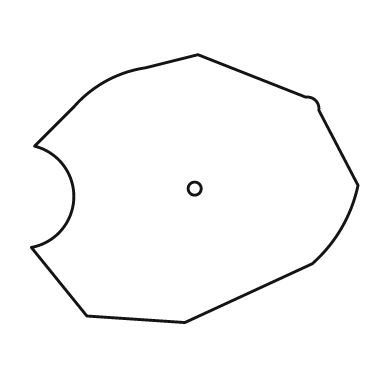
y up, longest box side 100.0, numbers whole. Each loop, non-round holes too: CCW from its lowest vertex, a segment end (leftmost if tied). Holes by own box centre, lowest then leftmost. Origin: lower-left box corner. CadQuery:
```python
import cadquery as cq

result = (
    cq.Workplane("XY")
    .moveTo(47.0, 0.0)
    .lineTo(86.0, 18.0)
    .threePointArc((95.0, 29.0), (100.0, 42.0))
    .lineTo(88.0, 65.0)
    .threePointArc((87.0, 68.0), (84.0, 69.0))
    .lineTo(51.0, 82.0)
    .lineTo(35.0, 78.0)
    .threePointArc((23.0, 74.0), (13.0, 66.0))
    .lineTo(1.0, 54.0)
    .threePointArc((13.0, 38.0), (0.0, 23.0))
    .lineTo(17.0, 2.0)
    .close()
    .moveTo(50.0, 41.0)
    .circle(2.0)
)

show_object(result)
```